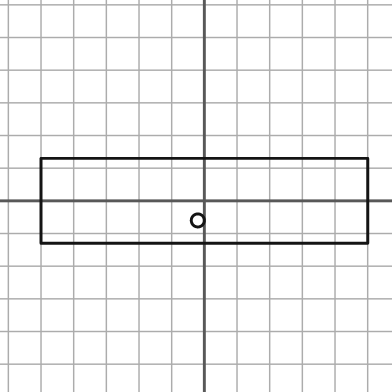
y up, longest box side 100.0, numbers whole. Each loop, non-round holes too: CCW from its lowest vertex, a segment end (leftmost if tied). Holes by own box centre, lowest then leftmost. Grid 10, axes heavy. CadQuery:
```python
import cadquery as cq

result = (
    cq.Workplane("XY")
    .moveTo(-50.0, -13.0)
    .lineTo(50.0, -13.0)
    .lineTo(50.0, 13.0)
    .lineTo(-50.0, 13.0)
    .close()
    .moveTo(-2.0, -6.0)
    .circle(2.0)
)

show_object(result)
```